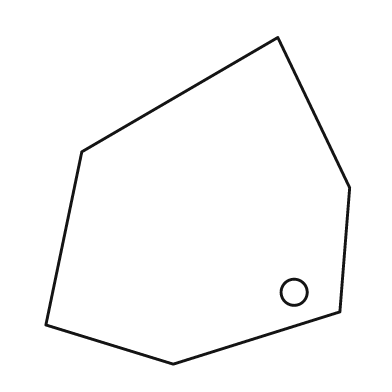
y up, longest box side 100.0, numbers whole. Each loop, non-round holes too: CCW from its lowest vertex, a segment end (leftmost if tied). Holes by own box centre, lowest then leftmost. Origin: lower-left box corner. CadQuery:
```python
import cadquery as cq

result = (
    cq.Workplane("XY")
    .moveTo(39.0, 0.0)
    .lineTo(90.0, 16.0)
    .lineTo(93.0, 54.0)
    .lineTo(71.0, 100.0)
    .lineTo(11.0, 65.0)
    .lineTo(0.0, 12.0)
    .close()
    .moveTo(76.0, 22.0)
    .circle(4.0)
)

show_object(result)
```